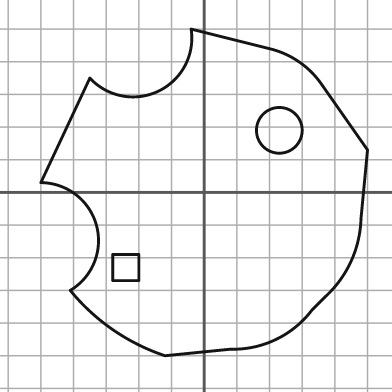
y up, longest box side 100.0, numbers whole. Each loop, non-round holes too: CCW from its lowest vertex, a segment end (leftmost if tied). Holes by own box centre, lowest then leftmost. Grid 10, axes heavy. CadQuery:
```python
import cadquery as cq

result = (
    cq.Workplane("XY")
    .moveTo(-12.0, -50.0)
    .lineTo(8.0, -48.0)
    .threePointArc((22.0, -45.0), (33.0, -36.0))
    .lineTo(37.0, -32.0)
    .threePointArc((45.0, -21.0), (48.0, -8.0))
    .lineTo(50.0, 13.0)
    .lineTo(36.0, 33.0)
    .threePointArc((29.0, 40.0), (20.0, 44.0))
    .lineTo(-4.0, 50.0)
    .threePointArc((-14.0, 31.0), (-35.0, 35.0))
    .lineTo(-50.0, 3.0)
    .threePointArc((-33.0, -10.0), (-41.0, -30.0))
    .threePointArc((-28.0, -42.0), (-12.0, -50.0))
    .close()
    .moveTo(-28.0, -27.0)
    .lineTo(-20.0, -27.0)
    .lineTo(-20.0, -19.0)
    .lineTo(-28.0, -19.0)
    .close()
    .moveTo(23.0, 19.0)
    .circle(7.0)
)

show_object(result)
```